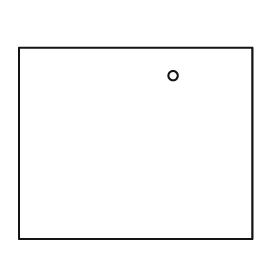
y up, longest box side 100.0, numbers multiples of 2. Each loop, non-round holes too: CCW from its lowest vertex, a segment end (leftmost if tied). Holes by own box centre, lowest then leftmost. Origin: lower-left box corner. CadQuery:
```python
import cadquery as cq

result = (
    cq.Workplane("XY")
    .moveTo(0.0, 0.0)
    .lineTo(100.0, 0.0)
    .lineTo(100.0, 82.0)
    .lineTo(0.0, 82.0)
    .close()
    .moveTo(66.0, 70.0)
    .circle(2.0)
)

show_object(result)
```